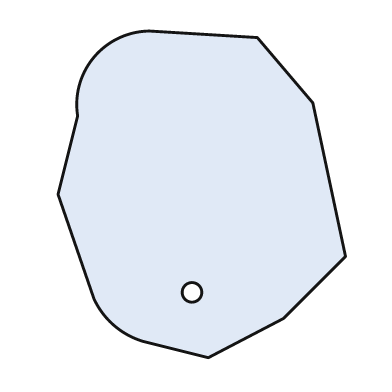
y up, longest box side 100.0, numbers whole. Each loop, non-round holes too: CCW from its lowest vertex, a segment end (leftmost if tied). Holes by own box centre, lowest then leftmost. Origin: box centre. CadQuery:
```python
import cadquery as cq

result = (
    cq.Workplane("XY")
    .moveTo(2.0, -50.0)
    .lineTo(25.0, -38.0)
    .lineTo(44.0, -19.0)
    .lineTo(34.0, 28.0)
    .lineTo(17.0, 48.0)
    .lineTo(-16.0, 50.0)
    .threePointArc((-33.0, 42.0), (-38.0, 24.0))
    .lineTo(-44.0, 0.0)
    .lineTo(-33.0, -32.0)
    .threePointArc((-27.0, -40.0), (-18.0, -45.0))
    .close()
    .moveTo(-3.0, -30.0)
    .circle(3.0)
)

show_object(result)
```